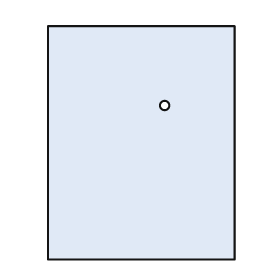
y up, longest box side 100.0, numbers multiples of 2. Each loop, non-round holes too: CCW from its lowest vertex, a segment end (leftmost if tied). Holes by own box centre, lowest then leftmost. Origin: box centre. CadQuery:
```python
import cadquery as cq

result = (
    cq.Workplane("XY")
    .moveTo(-40.0, -50.0)
    .lineTo(40.0, -50.0)
    .lineTo(40.0, 50.0)
    .lineTo(-40.0, 50.0)
    .close()
    .moveTo(10.0, 16.0)
    .circle(2.0)
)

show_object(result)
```